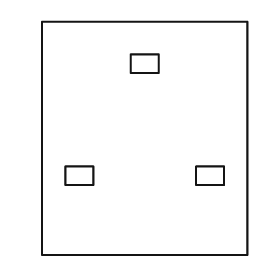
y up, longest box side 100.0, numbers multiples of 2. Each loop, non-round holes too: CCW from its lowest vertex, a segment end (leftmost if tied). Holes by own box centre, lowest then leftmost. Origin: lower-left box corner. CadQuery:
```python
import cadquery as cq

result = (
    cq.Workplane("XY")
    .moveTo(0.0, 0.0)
    .lineTo(88.0, 0.0)
    .lineTo(88.0, 100.0)
    .lineTo(0.0, 100.0)
    .close()
    .moveTo(10.0, 30.0)
    .lineTo(22.0, 30.0)
    .lineTo(22.0, 38.0)
    .lineTo(10.0, 38.0)
    .close()
    .moveTo(66.0, 30.0)
    .lineTo(78.0, 30.0)
    .lineTo(78.0, 38.0)
    .lineTo(66.0, 38.0)
    .close()
    .moveTo(38.0, 78.0)
    .lineTo(50.0, 78.0)
    .lineTo(50.0, 86.0)
    .lineTo(38.0, 86.0)
    .close()
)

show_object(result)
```